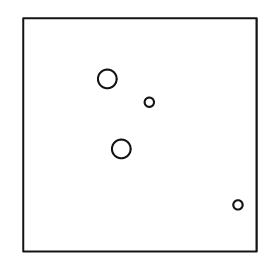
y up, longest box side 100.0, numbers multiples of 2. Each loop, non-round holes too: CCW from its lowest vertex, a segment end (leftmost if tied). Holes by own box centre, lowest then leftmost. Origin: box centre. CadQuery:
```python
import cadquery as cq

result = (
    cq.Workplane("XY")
    .moveTo(-50.0, -50.0)
    .lineTo(50.0, -50.0)
    .lineTo(50.0, 50.0)
    .lineTo(-50.0, 50.0)
    .close()
    .moveTo(42.0, -30.0)
    .circle(2.0)
    .moveTo(-8.0, -6.0)
    .circle(4.0)
    .moveTo(4.0, 14.0)
    .circle(2.0)
    .moveTo(-14.0, 24.0)
    .circle(4.0)
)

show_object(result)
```